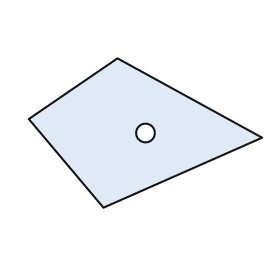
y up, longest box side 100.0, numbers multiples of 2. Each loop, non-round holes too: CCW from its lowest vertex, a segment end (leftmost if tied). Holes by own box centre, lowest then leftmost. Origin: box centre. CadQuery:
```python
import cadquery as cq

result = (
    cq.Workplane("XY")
    .moveTo(-18.0, -32.0)
    .lineTo(50.0, -2.0)
    .lineTo(-12.0, 32.0)
    .lineTo(-50.0, 6.0)
    .close()
    .moveTo(0.0, 0.0)
    .circle(4.0)
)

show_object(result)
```